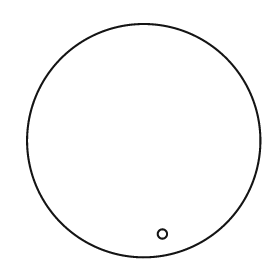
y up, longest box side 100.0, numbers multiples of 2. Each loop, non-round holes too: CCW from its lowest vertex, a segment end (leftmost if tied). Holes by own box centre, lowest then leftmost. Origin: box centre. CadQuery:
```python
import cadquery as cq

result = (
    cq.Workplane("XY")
    .moveTo(0.0, 0.0)
    .circle(50.0)
    .moveTo(8.0, -40.0)
    .circle(2.0)
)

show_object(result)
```